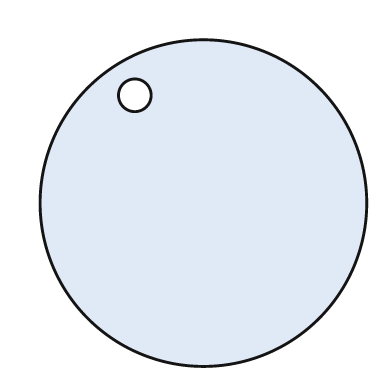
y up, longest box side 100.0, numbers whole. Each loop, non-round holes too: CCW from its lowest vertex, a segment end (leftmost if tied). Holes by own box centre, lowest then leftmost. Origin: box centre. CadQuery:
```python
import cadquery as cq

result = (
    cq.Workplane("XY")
    .moveTo(0.0, 0.0)
    .circle(50.0)
    .moveTo(-21.0, 33.0)
    .circle(5.0)
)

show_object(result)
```